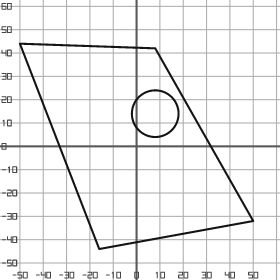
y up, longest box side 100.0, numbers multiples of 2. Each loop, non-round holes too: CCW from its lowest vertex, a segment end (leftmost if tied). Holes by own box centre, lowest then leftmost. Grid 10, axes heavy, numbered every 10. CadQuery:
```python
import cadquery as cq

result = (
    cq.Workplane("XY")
    .moveTo(-16.0, -44.0)
    .lineTo(50.0, -32.0)
    .lineTo(8.0, 42.0)
    .lineTo(-50.0, 44.0)
    .close()
    .moveTo(8.0, 14.0)
    .circle(10.0)
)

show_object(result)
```